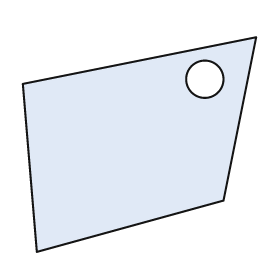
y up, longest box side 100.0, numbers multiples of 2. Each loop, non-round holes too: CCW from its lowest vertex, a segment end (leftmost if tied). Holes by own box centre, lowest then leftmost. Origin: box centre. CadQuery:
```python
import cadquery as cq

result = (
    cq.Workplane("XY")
    .moveTo(-44.0, -46.0)
    .lineTo(36.0, -24.0)
    .lineTo(50.0, 46.0)
    .lineTo(-50.0, 26.0)
    .close()
    .moveTo(28.0, 28.0)
    .circle(8.0)
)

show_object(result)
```